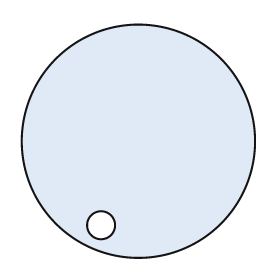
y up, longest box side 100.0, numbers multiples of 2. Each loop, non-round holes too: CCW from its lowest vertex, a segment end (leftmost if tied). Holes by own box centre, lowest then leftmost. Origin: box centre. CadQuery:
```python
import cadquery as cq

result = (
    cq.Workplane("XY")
    .moveTo(0.0, 0.0)
    .circle(50.0)
    .moveTo(-16.0, -36.0)
    .circle(6.0)
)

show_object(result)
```